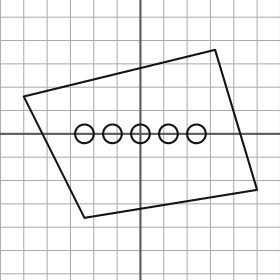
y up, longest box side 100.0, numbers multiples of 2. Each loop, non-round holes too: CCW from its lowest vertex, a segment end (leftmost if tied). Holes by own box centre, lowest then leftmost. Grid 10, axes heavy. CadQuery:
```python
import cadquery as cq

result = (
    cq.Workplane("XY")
    .moveTo(-24.0, -36.0)
    .lineTo(50.0, -24.0)
    .lineTo(32.0, 36.0)
    .lineTo(-50.0, 16.0)
    .close()
    .moveTo(-24.0, 0.0)
    .circle(4.0)
    .moveTo(-12.0, 0.0)
    .circle(4.0)
    .moveTo(0.0, 0.0)
    .circle(4.0)
    .moveTo(12.0, 0.0)
    .circle(4.0)
    .moveTo(24.0, 0.0)
    .circle(4.0)
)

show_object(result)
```